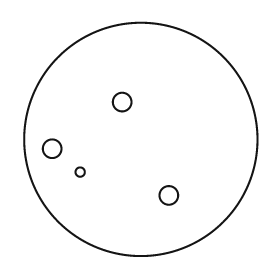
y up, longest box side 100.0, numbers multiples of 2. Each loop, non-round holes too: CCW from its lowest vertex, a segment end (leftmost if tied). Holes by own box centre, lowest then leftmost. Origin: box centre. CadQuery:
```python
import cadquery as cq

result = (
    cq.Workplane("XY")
    .moveTo(0.0, 0.0)
    .circle(50.0)
    .moveTo(12.0, -24.0)
    .circle(4.0)
    .moveTo(-26.0, -14.0)
    .circle(2.0)
    .moveTo(-38.0, -4.0)
    .circle(4.0)
    .moveTo(-8.0, 16.0)
    .circle(4.0)
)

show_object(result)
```